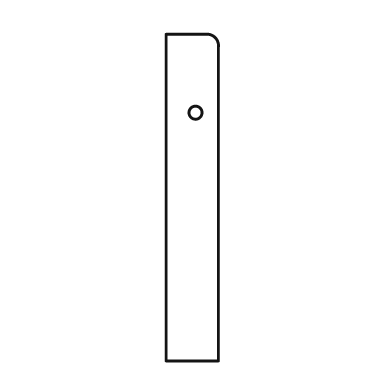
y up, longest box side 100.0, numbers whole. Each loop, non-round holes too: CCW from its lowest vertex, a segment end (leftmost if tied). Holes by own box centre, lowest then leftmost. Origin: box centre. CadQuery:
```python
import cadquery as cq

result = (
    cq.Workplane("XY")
    .moveTo(-8.0, -50.0)
    .lineTo(8.0, -50.0)
    .lineTo(8.0, 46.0)
    .threePointArc((7.0, 49.0), (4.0, 50.0))
    .lineTo(-8.0, 50.0)
    .close()
    .moveTo(1.0, 26.0)
    .circle(2.0)
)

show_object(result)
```